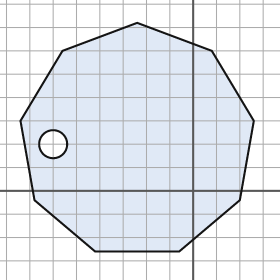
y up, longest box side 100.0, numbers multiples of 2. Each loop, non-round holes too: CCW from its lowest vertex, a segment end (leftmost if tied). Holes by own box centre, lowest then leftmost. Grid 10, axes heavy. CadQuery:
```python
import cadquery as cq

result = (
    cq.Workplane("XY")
    .moveTo(-42.0, -26.0)
    .lineTo(-6.0, -26.0)
    .lineTo(20.0, -4.0)
    .lineTo(26.0, 30.0)
    .lineTo(8.0, 60.0)
    .lineTo(-24.0, 72.0)
    .lineTo(-56.0, 60.0)
    .lineTo(-74.0, 30.0)
    .lineTo(-68.0, -4.0)
    .close()
    .moveTo(-60.0, 20.0)
    .circle(6.0)
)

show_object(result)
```